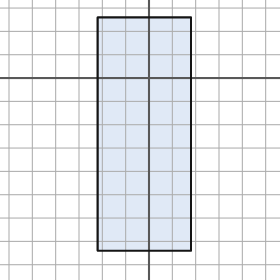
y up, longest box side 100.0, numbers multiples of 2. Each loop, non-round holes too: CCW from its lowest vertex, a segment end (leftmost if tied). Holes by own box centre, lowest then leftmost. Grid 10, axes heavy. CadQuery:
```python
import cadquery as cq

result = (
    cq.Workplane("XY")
    .moveTo(-22.0, -74.0)
    .lineTo(18.0, -74.0)
    .lineTo(18.0, 26.0)
    .lineTo(-22.0, 26.0)
    .close()
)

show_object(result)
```